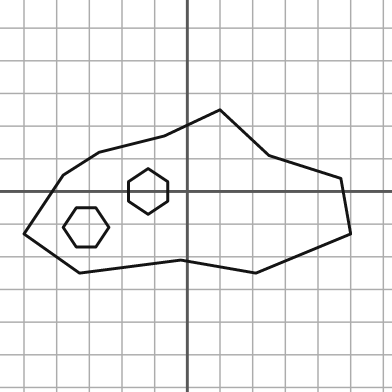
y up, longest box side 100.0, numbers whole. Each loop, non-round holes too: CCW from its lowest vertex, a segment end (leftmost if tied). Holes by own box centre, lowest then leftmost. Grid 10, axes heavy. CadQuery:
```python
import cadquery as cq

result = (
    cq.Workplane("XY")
    .moveTo(-33.0, -25.0)
    .lineTo(-2.0, -21.0)
    .lineTo(21.0, -25.0)
    .lineTo(50.0, -13.0)
    .lineTo(47.0, 4.0)
    .lineTo(25.0, 11.0)
    .lineTo(10.0, 25.0)
    .lineTo(-7.0, 17.0)
    .lineTo(-27.0, 12.0)
    .lineTo(-38.0, 5.0)
    .lineTo(-50.0, -13.0)
    .close()
    .moveTo(-34.0, -17.0)
    .lineTo(-28.0, -17.0)
    .lineTo(-24.0, -11.0)
    .lineTo(-28.0, -5.0)
    .lineTo(-34.0, -5.0)
    .lineTo(-38.0, -11.0)
    .close()
    .moveTo(-12.0, -7.0)
    .lineTo(-6.0, -3.0)
    .lineTo(-6.0, 3.0)
    .lineTo(-12.0, 7.0)
    .lineTo(-18.0, 3.0)
    .lineTo(-18.0, -3.0)
    .close()
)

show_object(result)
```